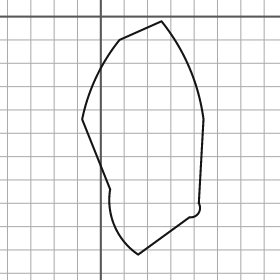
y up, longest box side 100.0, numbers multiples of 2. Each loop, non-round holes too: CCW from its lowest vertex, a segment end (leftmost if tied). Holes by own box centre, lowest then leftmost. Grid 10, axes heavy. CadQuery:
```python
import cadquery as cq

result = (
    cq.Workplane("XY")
    .moveTo(16.0, -102.0)
    .lineTo(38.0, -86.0)
    .threePointArc((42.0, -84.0), (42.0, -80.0))
    .lineTo(44.0, -44.0)
    .threePointArc((38.0, -22.0), (26.0, -2.0))
    .lineTo(8.0, -10.0)
    .threePointArc((-2.0, -26.0), (-8.0, -44.0))
    .lineTo(4.0, -74.0)
    .threePointArc((6.0, -90.0), (16.0, -102.0))
    .close()
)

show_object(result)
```